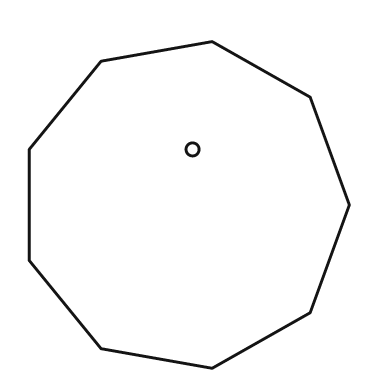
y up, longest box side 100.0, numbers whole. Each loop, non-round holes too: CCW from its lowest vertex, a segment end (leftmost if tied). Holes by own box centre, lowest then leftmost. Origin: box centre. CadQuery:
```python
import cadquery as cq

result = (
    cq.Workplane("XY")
    .moveTo(7.0, -50.0)
    .lineTo(37.0, -33.0)
    .lineTo(49.0, 0.0)
    .lineTo(37.0, 33.0)
    .lineTo(7.0, 50.0)
    .lineTo(-27.0, 44.0)
    .lineTo(-49.0, 17.0)
    .lineTo(-49.0, -17.0)
    .lineTo(-27.0, -44.0)
    .close()
    .moveTo(1.0, 17.0)
    .circle(2.0)
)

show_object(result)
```